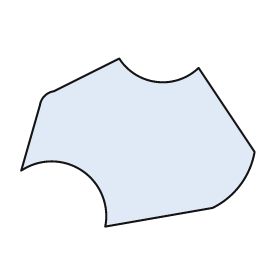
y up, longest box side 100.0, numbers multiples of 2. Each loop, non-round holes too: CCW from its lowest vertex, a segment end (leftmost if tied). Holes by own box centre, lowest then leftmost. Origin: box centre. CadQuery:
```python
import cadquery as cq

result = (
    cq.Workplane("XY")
    .moveTo(-14.0, -36.0)
    .lineTo(32.0, -28.0)
    .threePointArc((44.0, -18.0), (50.0, -4.0))
    .lineTo(26.0, 32.0)
    .threePointArc((8.0, 26.0), (-8.0, 36.0))
    .lineTo(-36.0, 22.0)
    .threePointArc((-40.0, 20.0), (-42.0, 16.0))
    .lineTo(-50.0, -12.0)
    .threePointArc((-24.0, -12.0), (-14.0, -36.0))
    .close()
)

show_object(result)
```